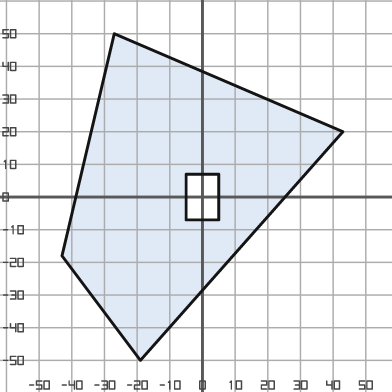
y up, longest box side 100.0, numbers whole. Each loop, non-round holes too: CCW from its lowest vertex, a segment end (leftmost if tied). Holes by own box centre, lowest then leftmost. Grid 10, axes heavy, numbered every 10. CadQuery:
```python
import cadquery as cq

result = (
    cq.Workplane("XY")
    .moveTo(-19.0, -50.0)
    .lineTo(43.0, 20.0)
    .lineTo(-27.0, 50.0)
    .lineTo(-43.0, -18.0)
    .close()
    .moveTo(-5.0, -7.0)
    .lineTo(5.0, -7.0)
    .lineTo(5.0, 7.0)
    .lineTo(-5.0, 7.0)
    .close()
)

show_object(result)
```